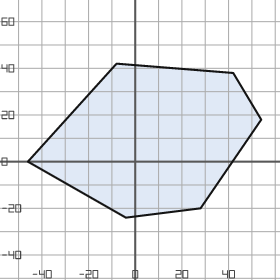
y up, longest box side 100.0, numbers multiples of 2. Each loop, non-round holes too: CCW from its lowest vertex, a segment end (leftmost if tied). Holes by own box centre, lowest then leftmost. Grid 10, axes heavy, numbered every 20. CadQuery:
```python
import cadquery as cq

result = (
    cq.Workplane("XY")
    .moveTo(-4.0, -24.0)
    .lineTo(28.0, -20.0)
    .lineTo(54.0, 18.0)
    .lineTo(42.0, 38.0)
    .lineTo(-8.0, 42.0)
    .lineTo(-46.0, 0.0)
    .close()
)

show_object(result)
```